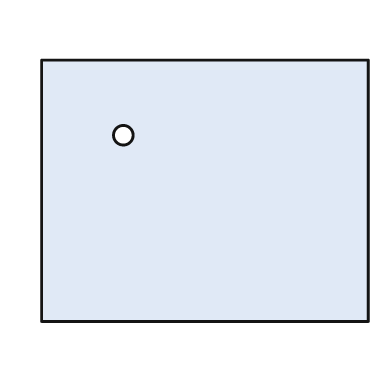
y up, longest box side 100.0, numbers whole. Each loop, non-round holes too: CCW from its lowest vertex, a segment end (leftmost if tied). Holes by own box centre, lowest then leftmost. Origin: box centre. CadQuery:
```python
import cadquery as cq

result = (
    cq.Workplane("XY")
    .moveTo(-50.0, -40.0)
    .lineTo(50.0, -40.0)
    .lineTo(50.0, 40.0)
    .lineTo(-50.0, 40.0)
    .close()
    .moveTo(-25.0, 17.0)
    .circle(3.0)
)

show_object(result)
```